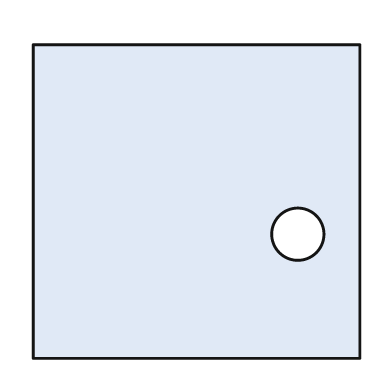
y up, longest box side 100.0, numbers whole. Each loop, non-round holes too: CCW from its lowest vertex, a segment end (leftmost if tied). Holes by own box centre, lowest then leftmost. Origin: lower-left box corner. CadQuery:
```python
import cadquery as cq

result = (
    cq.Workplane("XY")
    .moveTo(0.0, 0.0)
    .lineTo(100.0, 0.0)
    .lineTo(100.0, 96.0)
    .lineTo(0.0, 96.0)
    .close()
    .moveTo(81.0, 38.0)
    .circle(8.0)
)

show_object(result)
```